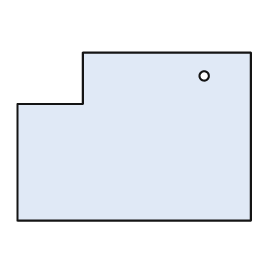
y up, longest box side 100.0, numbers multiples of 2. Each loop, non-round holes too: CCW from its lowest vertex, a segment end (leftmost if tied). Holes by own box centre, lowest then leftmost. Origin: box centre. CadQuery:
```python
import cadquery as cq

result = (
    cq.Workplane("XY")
    .moveTo(-50.0, -36.0)
    .lineTo(50.0, -36.0)
    .lineTo(50.0, 36.0)
    .lineTo(-22.0, 36.0)
    .lineTo(-22.0, 14.0)
    .lineTo(-50.0, 14.0)
    .close()
    .moveTo(30.0, 26.0)
    .circle(2.0)
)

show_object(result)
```